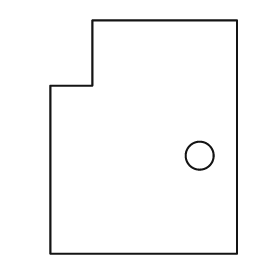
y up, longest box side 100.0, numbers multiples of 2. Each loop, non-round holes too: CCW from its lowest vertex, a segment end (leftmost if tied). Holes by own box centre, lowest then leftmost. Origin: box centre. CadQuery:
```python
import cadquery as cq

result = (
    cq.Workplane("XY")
    .moveTo(-40.0, -50.0)
    .lineTo(40.0, -50.0)
    .lineTo(40.0, 50.0)
    .lineTo(-22.0, 50.0)
    .lineTo(-22.0, 22.0)
    .lineTo(-40.0, 22.0)
    .close()
    .moveTo(24.0, -8.0)
    .circle(6.0)
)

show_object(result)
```